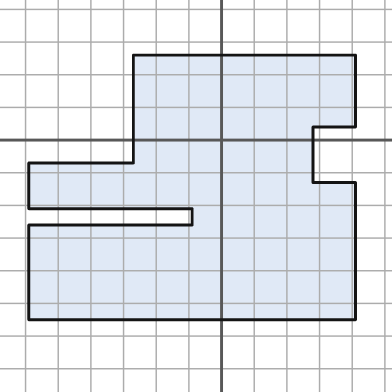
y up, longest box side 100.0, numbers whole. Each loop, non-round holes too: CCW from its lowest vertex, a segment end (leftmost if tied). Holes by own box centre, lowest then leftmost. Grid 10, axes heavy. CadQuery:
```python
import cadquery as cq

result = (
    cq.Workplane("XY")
    .moveTo(-59.0, -55.0)
    .lineTo(41.0, -55.0)
    .lineTo(41.0, -13.0)
    .lineTo(28.0, -13.0)
    .lineTo(28.0, 4.0)
    .lineTo(41.0, 4.0)
    .lineTo(41.0, 26.0)
    .lineTo(-27.0, 26.0)
    .lineTo(-27.0, -7.0)
    .lineTo(-59.0, -7.0)
    .lineTo(-59.0, -21.0)
    .lineTo(-9.0, -21.0)
    .lineTo(-9.0, -26.0)
    .lineTo(-59.0, -26.0)
    .close()
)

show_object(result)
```